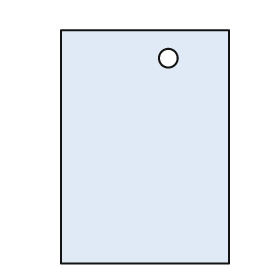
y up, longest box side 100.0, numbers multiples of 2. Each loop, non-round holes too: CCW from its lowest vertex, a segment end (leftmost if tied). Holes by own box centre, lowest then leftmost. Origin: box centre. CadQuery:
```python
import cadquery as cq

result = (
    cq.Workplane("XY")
    .moveTo(-36.0, -50.0)
    .lineTo(36.0, -50.0)
    .lineTo(36.0, 50.0)
    .lineTo(-36.0, 50.0)
    .close()
    .moveTo(10.0, 38.0)
    .circle(4.0)
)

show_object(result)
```